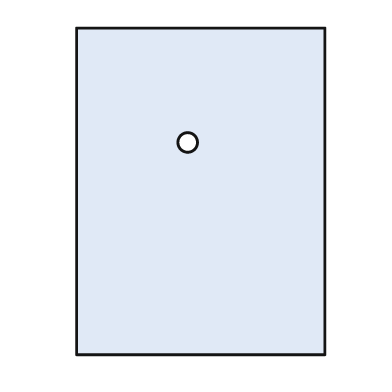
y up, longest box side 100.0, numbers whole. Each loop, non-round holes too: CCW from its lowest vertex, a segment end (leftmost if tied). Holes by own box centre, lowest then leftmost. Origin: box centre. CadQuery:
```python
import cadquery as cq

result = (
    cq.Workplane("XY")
    .moveTo(-38.0, -50.0)
    .lineTo(38.0, -50.0)
    .lineTo(38.0, 50.0)
    .lineTo(-38.0, 50.0)
    .close()
    .moveTo(-4.0, 15.0)
    .circle(3.0)
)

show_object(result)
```